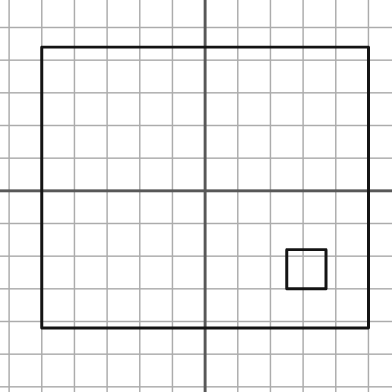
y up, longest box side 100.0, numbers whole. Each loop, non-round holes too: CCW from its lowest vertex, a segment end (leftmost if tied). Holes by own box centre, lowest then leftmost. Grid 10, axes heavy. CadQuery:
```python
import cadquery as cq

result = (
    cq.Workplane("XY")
    .moveTo(-50.0, -42.0)
    .lineTo(50.0, -42.0)
    .lineTo(50.0, 44.0)
    .lineTo(-50.0, 44.0)
    .close()
    .moveTo(25.0, -30.0)
    .lineTo(37.0, -30.0)
    .lineTo(37.0, -18.0)
    .lineTo(25.0, -18.0)
    .close()
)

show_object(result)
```